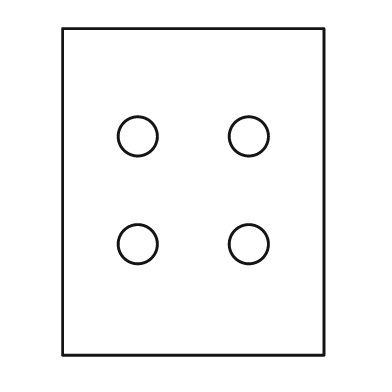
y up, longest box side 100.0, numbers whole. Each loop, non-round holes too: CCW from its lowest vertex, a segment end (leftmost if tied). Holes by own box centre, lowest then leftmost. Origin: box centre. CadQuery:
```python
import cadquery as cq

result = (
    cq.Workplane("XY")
    .moveTo(-40.0, -50.0)
    .lineTo(40.0, -50.0)
    .lineTo(40.0, 50.0)
    .lineTo(-40.0, 50.0)
    .close()
    .moveTo(-17.0, -16.0)
    .circle(6.0)
    .moveTo(17.0, -16.0)
    .circle(6.0)
    .moveTo(-17.0, 17.0)
    .circle(6.0)
    .moveTo(17.0, 17.0)
    .circle(6.0)
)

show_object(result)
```